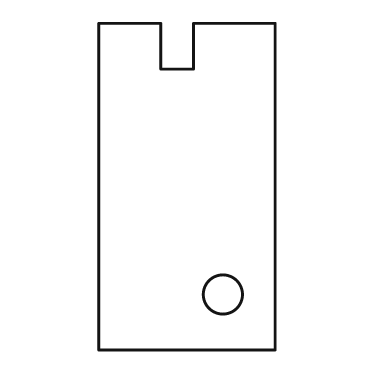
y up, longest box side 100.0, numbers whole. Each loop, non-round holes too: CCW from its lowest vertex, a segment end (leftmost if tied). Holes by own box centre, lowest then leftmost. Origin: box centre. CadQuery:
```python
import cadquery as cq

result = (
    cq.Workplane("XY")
    .moveTo(-27.0, -50.0)
    .lineTo(27.0, -50.0)
    .lineTo(27.0, 50.0)
    .lineTo(2.0, 50.0)
    .lineTo(2.0, 36.0)
    .lineTo(-8.0, 36.0)
    .lineTo(-8.0, 50.0)
    .lineTo(-27.0, 50.0)
    .close()
    .moveTo(11.0, -33.0)
    .circle(6.0)
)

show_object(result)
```